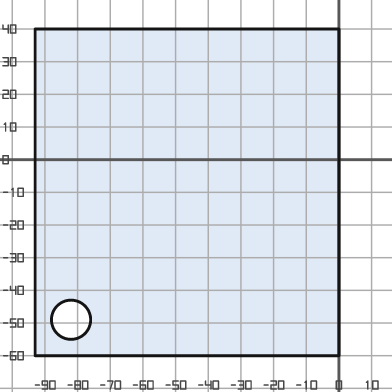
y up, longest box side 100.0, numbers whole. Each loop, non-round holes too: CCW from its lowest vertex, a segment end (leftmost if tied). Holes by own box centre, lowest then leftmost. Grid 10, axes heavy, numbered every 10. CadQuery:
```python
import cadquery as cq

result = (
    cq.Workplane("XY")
    .moveTo(-93.0, -60.0)
    .lineTo(0.0, -60.0)
    .lineTo(0.0, 40.0)
    .lineTo(-93.0, 40.0)
    .close()
    .moveTo(-82.0, -49.0)
    .circle(6.0)
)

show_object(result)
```